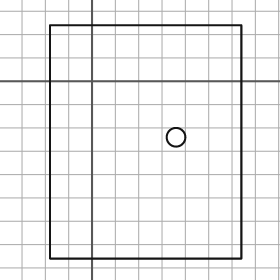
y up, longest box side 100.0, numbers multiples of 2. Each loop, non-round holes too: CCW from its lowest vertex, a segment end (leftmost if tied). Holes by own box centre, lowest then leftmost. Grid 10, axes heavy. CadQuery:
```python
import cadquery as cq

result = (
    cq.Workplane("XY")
    .moveTo(-18.0, -76.0)
    .lineTo(64.0, -76.0)
    .lineTo(64.0, 24.0)
    .lineTo(-18.0, 24.0)
    .close()
    .moveTo(36.0, -24.0)
    .circle(4.0)
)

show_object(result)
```